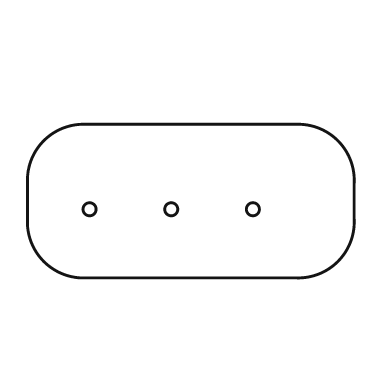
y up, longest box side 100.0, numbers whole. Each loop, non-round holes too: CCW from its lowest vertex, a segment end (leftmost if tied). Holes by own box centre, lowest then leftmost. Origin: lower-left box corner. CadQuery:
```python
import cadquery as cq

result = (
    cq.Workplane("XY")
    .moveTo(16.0, 0.0)
    .lineTo(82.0, 0.0)
    .threePointArc((95.0, 5.0), (100.0, 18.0))
    .lineTo(100.0, 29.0)
    .threePointArc((95.0, 42.0), (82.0, 47.0))
    .lineTo(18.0, 47.0)
    .threePointArc((5.0, 42.0), (0.0, 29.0))
    .lineTo(0.0, 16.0)
    .threePointArc((5.0, 5.0), (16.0, 0.0))
    .close()
    .moveTo(19.0, 21.0)
    .circle(2.0)
    .moveTo(44.0, 21.0)
    .circle(2.0)
    .moveTo(69.0, 21.0)
    .circle(2.0)
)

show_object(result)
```